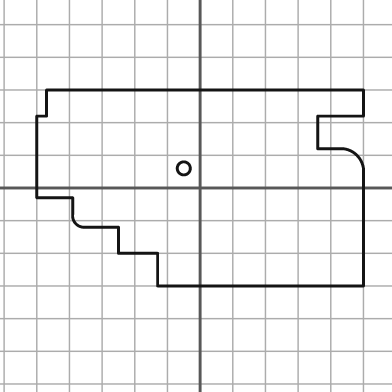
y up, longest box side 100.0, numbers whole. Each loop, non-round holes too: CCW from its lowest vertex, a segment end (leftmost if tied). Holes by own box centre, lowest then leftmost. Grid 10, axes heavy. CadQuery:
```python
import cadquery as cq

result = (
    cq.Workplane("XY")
    .moveTo(-13.0, -30.0)
    .lineTo(50.0, -30.0)
    .lineTo(50.0, 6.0)
    .threePointArc((48.0, 10.0), (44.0, 12.0))
    .lineTo(36.0, 12.0)
    .lineTo(36.0, 22.0)
    .lineTo(50.0, 22.0)
    .lineTo(50.0, 30.0)
    .lineTo(-47.0, 30.0)
    .lineTo(-47.0, 22.0)
    .lineTo(-50.0, 22.0)
    .lineTo(-50.0, -3.0)
    .lineTo(-39.0, -3.0)
    .lineTo(-39.0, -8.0)
    .threePointArc((-38.0, -11.0), (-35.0, -12.0))
    .lineTo(-25.0, -12.0)
    .lineTo(-25.0, -20.0)
    .lineTo(-13.0, -20.0)
    .close()
    .moveTo(-5.0, 6.0)
    .circle(2.0)
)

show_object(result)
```